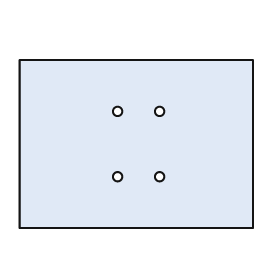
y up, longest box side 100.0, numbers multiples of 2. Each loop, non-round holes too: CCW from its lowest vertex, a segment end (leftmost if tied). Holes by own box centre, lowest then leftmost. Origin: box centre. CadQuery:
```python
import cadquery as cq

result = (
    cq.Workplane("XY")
    .moveTo(-50.0, -36.0)
    .lineTo(50.0, -36.0)
    .lineTo(50.0, 36.0)
    .lineTo(-50.0, 36.0)
    .close()
    .moveTo(-8.0, -14.0)
    .circle(2.0)
    .moveTo(10.0, -14.0)
    .circle(2.0)
    .moveTo(-8.0, 14.0)
    .circle(2.0)
    .moveTo(10.0, 14.0)
    .circle(2.0)
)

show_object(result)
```